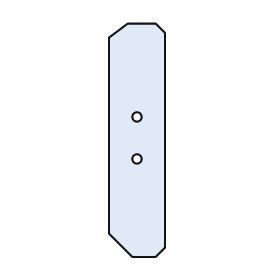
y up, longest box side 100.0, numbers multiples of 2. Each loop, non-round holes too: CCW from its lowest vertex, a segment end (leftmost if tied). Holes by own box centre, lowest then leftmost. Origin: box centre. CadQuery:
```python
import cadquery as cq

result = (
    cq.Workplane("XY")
    .moveTo(-2.0, -50.0)
    .lineTo(8.0, -50.0)
    .lineTo(12.0, -46.0)
    .lineTo(12.0, 46.0)
    .lineTo(8.0, 50.0)
    .lineTo(-4.0, 50.0)
    .lineTo(-12.0, 44.0)
    .lineTo(-12.0, -40.0)
    .close()
    .moveTo(0.0, -8.0)
    .circle(2.0)
    .moveTo(0.0, 10.0)
    .circle(2.0)
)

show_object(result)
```